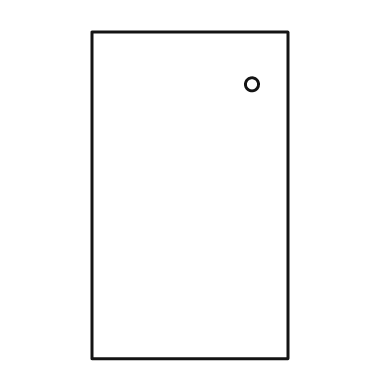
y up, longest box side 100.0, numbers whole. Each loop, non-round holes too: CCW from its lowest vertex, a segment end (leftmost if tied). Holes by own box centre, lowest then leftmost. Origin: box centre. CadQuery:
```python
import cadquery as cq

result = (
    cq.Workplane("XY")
    .moveTo(-30.0, -50.0)
    .lineTo(30.0, -50.0)
    .lineTo(30.0, 50.0)
    .lineTo(-30.0, 50.0)
    .close()
    .moveTo(19.0, 34.0)
    .circle(2.0)
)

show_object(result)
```